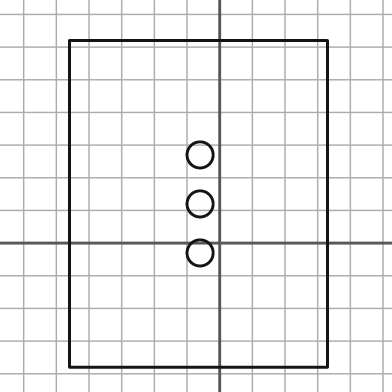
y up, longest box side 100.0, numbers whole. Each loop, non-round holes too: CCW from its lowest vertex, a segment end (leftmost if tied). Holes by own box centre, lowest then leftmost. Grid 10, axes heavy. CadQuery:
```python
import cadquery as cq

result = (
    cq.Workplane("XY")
    .moveTo(-46.0, -38.0)
    .lineTo(33.0, -38.0)
    .lineTo(33.0, 62.0)
    .lineTo(-46.0, 62.0)
    .close()
    .moveTo(-6.0, -3.0)
    .circle(4.0)
    .moveTo(-6.0, 12.0)
    .circle(4.0)
    .moveTo(-6.0, 27.0)
    .circle(4.0)
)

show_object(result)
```